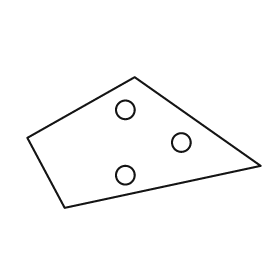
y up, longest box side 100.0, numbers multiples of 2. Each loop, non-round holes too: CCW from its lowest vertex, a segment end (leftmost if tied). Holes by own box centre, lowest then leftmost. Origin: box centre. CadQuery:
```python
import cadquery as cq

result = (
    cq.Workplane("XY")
    .moveTo(-34.0, -28.0)
    .lineTo(50.0, -10.0)
    .lineTo(-4.0, 28.0)
    .lineTo(-50.0, 2.0)
    .close()
    .moveTo(-8.0, -14.0)
    .circle(4.0)
    .moveTo(16.0, 0.0)
    .circle(4.0)
    .moveTo(-8.0, 14.0)
    .circle(4.0)
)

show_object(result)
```